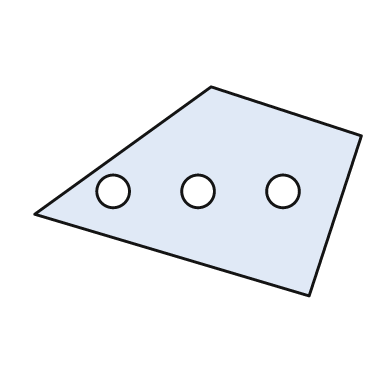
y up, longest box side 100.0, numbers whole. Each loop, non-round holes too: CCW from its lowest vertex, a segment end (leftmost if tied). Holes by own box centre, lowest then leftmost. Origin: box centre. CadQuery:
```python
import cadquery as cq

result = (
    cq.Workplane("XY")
    .moveTo(34.0, -32.0)
    .lineTo(50.0, 17.0)
    .lineTo(4.0, 32.0)
    .lineTo(-50.0, -7.0)
    .close()
    .moveTo(-26.0, 0.0)
    .circle(5.0)
    .moveTo(0.0, 0.0)
    .circle(5.0)
    .moveTo(26.0, 0.0)
    .circle(5.0)
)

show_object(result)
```